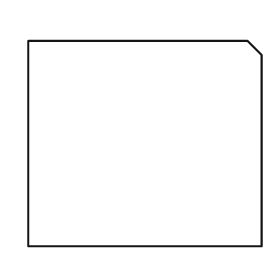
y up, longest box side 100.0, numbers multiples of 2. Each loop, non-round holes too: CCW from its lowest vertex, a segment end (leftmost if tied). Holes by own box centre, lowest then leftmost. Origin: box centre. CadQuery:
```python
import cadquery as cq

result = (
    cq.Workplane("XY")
    .moveTo(-50.0, -44.0)
    .lineTo(50.0, -44.0)
    .lineTo(50.0, 38.0)
    .lineTo(44.0, 44.0)
    .lineTo(-50.0, 44.0)
    .close()
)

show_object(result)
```